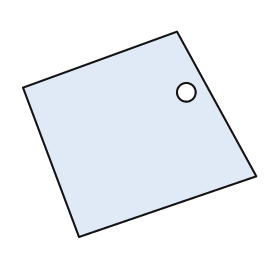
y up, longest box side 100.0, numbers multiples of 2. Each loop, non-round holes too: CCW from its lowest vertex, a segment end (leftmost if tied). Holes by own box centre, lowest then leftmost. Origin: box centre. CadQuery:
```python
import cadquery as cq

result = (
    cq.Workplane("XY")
    .moveTo(-26.0, -44.0)
    .lineTo(50.0, -18.0)
    .lineTo(16.0, 44.0)
    .lineTo(-50.0, 20.0)
    .close()
    .moveTo(20.0, 18.0)
    .circle(4.0)
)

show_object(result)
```